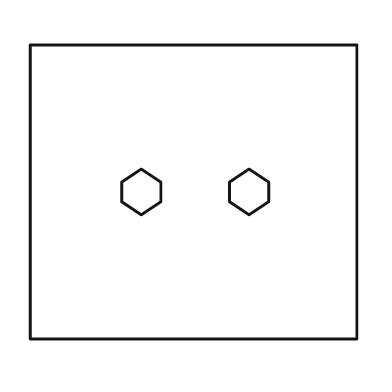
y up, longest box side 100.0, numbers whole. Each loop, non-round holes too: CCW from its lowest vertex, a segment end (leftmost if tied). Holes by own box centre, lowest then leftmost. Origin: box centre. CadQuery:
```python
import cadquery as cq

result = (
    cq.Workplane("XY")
    .moveTo(-50.0, -45.0)
    .lineTo(50.0, -45.0)
    .lineTo(50.0, 45.0)
    .lineTo(-50.0, 45.0)
    .close()
    .moveTo(-16.0, -7.0)
    .lineTo(-10.0, -3.0)
    .lineTo(-10.0, 3.0)
    .lineTo(-16.0, 7.0)
    .lineTo(-22.0, 3.0)
    .lineTo(-22.0, -3.0)
    .close()
    .moveTo(17.0, -7.0)
    .lineTo(23.0, -3.0)
    .lineTo(23.0, 3.0)
    .lineTo(17.0, 7.0)
    .lineTo(11.0, 3.0)
    .lineTo(11.0, -3.0)
    .close()
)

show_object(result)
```